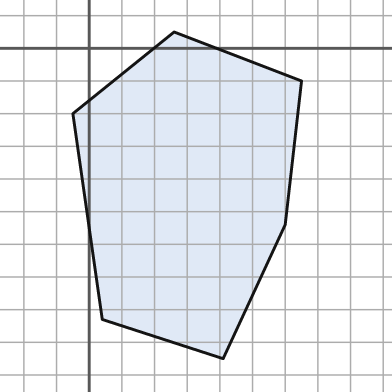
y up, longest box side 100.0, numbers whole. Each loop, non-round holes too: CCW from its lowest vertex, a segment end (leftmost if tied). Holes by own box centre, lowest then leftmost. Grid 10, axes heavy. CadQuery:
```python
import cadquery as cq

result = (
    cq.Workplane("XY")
    .moveTo(41.0, -95.0)
    .lineTo(60.0, -54.0)
    .lineTo(65.0, -10.0)
    .lineTo(26.0, 5.0)
    .lineTo(-5.0, -20.0)
    .lineTo(4.0, -83.0)
    .close()
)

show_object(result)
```